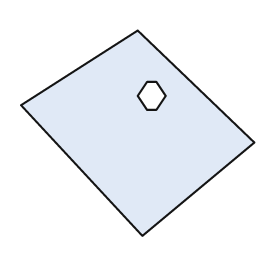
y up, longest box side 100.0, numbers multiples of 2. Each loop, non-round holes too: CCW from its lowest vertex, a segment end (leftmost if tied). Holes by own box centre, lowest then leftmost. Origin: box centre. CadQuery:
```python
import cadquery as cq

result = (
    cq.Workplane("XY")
    .moveTo(2.0, -44.0)
    .lineTo(50.0, -4.0)
    .lineTo(0.0, 44.0)
    .lineTo(-50.0, 12.0)
    .close()
    .moveTo(4.0, 10.0)
    .lineTo(8.0, 10.0)
    .lineTo(12.0, 16.0)
    .lineTo(8.0, 22.0)
    .lineTo(4.0, 22.0)
    .lineTo(0.0, 16.0)
    .close()
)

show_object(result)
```